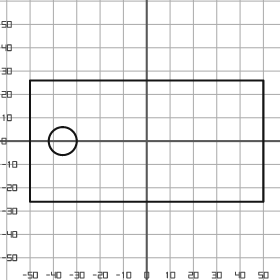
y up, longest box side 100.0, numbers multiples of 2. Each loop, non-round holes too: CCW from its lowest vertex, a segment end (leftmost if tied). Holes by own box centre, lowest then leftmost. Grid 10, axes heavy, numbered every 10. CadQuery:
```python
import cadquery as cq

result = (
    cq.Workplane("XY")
    .moveTo(-50.0, -26.0)
    .lineTo(50.0, -26.0)
    .lineTo(50.0, 26.0)
    .lineTo(-50.0, 26.0)
    .close()
    .moveTo(-36.0, 0.0)
    .circle(6.0)
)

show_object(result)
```